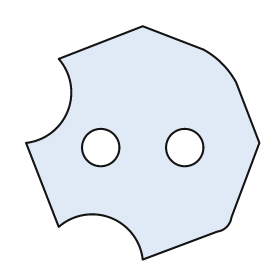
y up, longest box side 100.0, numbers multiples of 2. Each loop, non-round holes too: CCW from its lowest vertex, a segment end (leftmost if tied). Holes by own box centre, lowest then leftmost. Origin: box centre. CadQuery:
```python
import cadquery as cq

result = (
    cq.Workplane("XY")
    .moveTo(0.0, -50.0)
    .lineTo(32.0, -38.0)
    .threePointArc((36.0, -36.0), (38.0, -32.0))
    .lineTo(50.0, 0.0)
    .lineTo(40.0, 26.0)
    .threePointArc((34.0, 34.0), (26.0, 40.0))
    .lineTo(0.0, 50.0)
    .lineTo(-36.0, 36.0)
    .threePointArc((-32.0, 14.0), (-50.0, 0.0))
    .lineTo(-36.0, -36.0)
    .threePointArc((-14.0, -32.0), (0.0, -50.0))
    .close()
    .moveTo(-18.0, -2.0)
    .circle(8.0)
    .moveTo(18.0, -2.0)
    .circle(8.0)
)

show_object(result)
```